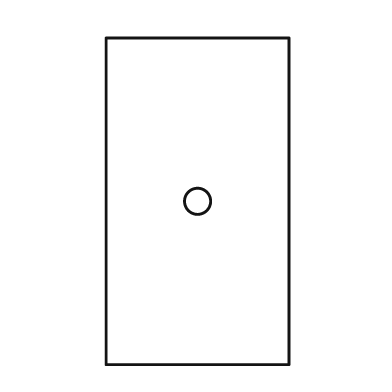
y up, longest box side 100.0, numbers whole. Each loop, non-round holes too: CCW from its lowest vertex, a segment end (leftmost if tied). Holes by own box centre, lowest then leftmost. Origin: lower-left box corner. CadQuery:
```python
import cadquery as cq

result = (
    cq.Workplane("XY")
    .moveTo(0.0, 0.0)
    .lineTo(56.0, 0.0)
    .lineTo(56.0, 100.0)
    .lineTo(0.0, 100.0)
    .close()
    .moveTo(28.0, 50.0)
    .circle(4.0)
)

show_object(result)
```